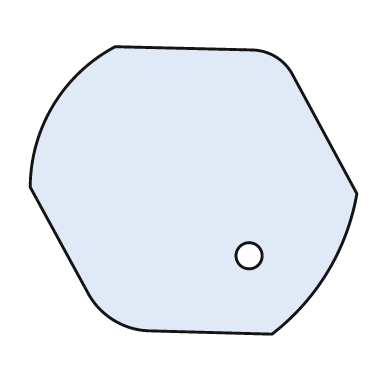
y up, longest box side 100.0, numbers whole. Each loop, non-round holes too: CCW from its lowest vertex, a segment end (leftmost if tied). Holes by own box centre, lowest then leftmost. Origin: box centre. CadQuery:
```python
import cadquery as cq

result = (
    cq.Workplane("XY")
    .moveTo(24.0, -44.0)
    .threePointArc((41.0, -25.0), (50.0, -1.0))
    .lineTo(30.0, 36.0)
    .threePointArc((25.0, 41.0), (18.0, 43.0))
    .lineTo(-24.0, 44.0)
    .threePointArc((-43.0, 26.0), (-50.0, 1.0))
    .lineTo(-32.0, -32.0)
    .threePointArc((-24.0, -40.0), (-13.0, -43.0))
    .close()
    .moveTo(17.0, -20.0)
    .circle(4.0)
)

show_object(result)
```